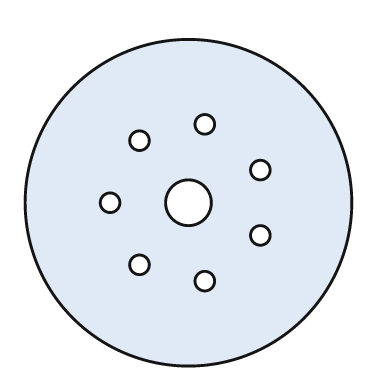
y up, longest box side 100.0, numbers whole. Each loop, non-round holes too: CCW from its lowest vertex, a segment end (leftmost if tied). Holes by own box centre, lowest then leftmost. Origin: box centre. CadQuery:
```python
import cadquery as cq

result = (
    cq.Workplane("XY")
    .moveTo(0.0, 0.0)
    .circle(50.0)
    .moveTo(5.0, -24.0)
    .circle(3.0)
    .moveTo(-15.0, -19.0)
    .circle(3.0)
    .moveTo(22.0, -10.0)
    .circle(3.0)
    .moveTo(-24.0, 0.0)
    .circle(3.0)
    .moveTo(0.0, 0.0)
    .circle(7.0)
    .moveTo(22.0, 10.0)
    .circle(3.0)
    .moveTo(-15.0, 19.0)
    .circle(3.0)
    .moveTo(5.0, 24.0)
    .circle(3.0)
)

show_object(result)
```